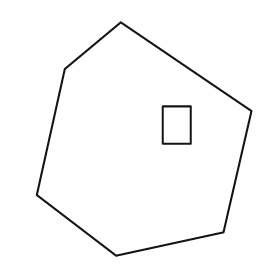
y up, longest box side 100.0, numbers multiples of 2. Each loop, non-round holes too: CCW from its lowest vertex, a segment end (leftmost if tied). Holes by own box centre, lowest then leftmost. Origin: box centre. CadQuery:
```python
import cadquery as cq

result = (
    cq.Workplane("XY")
    .moveTo(-12.0, -50.0)
    .lineTo(34.0, -40.0)
    .lineTo(46.0, 12.0)
    .lineTo(-10.0, 50.0)
    .lineTo(-34.0, 30.0)
    .lineTo(-46.0, -24.0)
    .close()
    .moveTo(8.0, -2.0)
    .lineTo(20.0, -2.0)
    .lineTo(20.0, 14.0)
    .lineTo(8.0, 14.0)
    .close()
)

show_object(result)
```